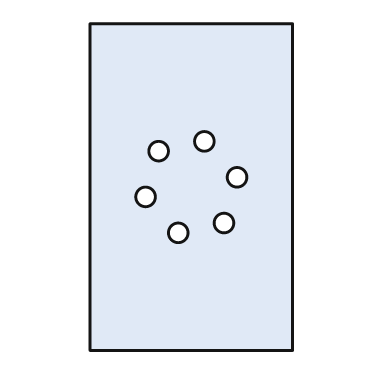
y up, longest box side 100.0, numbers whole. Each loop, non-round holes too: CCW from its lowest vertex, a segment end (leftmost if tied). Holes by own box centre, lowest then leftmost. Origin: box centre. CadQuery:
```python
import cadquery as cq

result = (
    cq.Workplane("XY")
    .moveTo(-31.0, -50.0)
    .lineTo(31.0, -50.0)
    .lineTo(31.0, 50.0)
    .lineTo(-31.0, 50.0)
    .close()
    .moveTo(-4.0, -14.0)
    .circle(3.0)
    .moveTo(10.0, -11.0)
    .circle(3.0)
    .moveTo(-14.0, -3.0)
    .circle(3.0)
    .moveTo(14.0, 3.0)
    .circle(3.0)
    .moveTo(-10.0, 11.0)
    .circle(3.0)
    .moveTo(4.0, 14.0)
    .circle(3.0)
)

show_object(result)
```